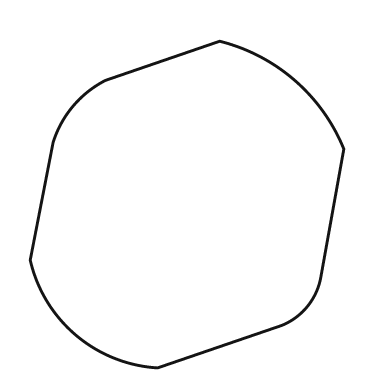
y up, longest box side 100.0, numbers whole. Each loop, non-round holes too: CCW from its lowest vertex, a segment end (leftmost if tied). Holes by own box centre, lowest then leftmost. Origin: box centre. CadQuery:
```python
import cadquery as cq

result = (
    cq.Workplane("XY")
    .moveTo(-9.0, -50.0)
    .lineTo(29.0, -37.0)
    .threePointArc((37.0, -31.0), (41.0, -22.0))
    .lineTo(48.0, 17.0)
    .threePointArc((33.0, 38.0), (10.0, 50.0))
    .lineTo(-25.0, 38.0)
    .threePointArc((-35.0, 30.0), (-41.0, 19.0))
    .lineTo(-48.0, -17.0)
    .threePointArc((-34.0, -40.0), (-9.0, -50.0))
    .close()
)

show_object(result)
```